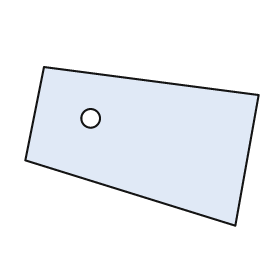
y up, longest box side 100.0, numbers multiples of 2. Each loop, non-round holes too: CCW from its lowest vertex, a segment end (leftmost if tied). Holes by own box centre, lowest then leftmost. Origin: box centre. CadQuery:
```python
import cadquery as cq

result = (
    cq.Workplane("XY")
    .moveTo(40.0, -34.0)
    .lineTo(50.0, 22.0)
    .lineTo(-42.0, 34.0)
    .lineTo(-50.0, -6.0)
    .close()
    .moveTo(-22.0, 12.0)
    .circle(4.0)
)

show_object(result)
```